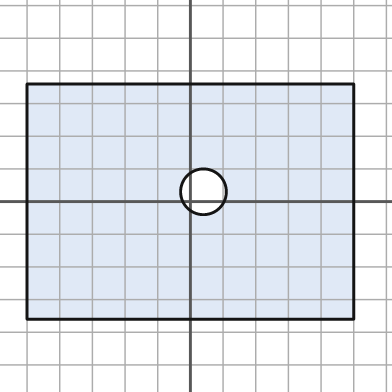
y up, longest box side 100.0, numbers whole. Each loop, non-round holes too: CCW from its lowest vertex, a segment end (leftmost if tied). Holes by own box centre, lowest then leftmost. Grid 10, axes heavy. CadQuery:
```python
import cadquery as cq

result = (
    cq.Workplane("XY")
    .moveTo(-50.0, -36.0)
    .lineTo(50.0, -36.0)
    .lineTo(50.0, 36.0)
    .lineTo(-50.0, 36.0)
    .close()
    .moveTo(4.0, 3.0)
    .circle(7.0)
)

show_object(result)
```